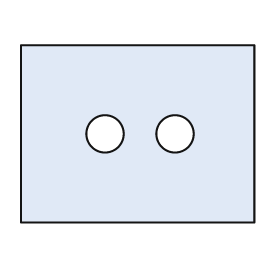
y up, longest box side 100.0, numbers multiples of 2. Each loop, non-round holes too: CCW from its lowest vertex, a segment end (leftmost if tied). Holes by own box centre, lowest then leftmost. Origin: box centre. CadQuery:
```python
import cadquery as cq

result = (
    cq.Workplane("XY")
    .moveTo(-50.0, -38.0)
    .lineTo(50.0, -38.0)
    .lineTo(50.0, 38.0)
    .lineTo(-50.0, 38.0)
    .close()
    .moveTo(-14.0, 0.0)
    .circle(8.0)
    .moveTo(16.0, 0.0)
    .circle(8.0)
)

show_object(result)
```